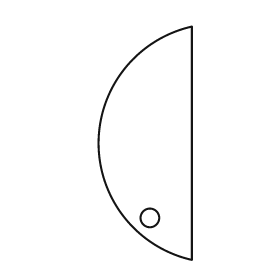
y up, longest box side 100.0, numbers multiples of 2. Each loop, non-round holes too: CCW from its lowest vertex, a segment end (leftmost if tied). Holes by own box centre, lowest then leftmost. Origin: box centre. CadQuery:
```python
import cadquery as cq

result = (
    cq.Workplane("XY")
    .moveTo(20.0, -50.0)
    .lineTo(20.0, 50.0)
    .threePointArc((-20.0, 0.0), (20.0, -50.0))
    .close()
    .moveTo(2.0, -32.0)
    .circle(4.0)
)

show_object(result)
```